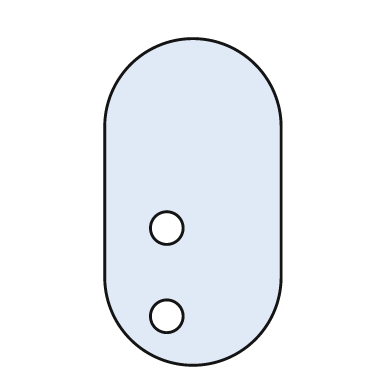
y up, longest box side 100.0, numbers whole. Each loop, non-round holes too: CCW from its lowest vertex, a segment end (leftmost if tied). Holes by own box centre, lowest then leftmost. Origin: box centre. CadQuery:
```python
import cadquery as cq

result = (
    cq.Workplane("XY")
    .moveTo(-27.0, -23.0)
    .threePointArc((0.0, -50.0), (27.0, -23.0))
    .lineTo(27.0, 23.0)
    .threePointArc((0.0, 50.0), (-27.0, 23.0))
    .close()
    .moveTo(-8.0, -35.0)
    .circle(5.0)
    .moveTo(-8.0, -8.0)
    .circle(5.0)
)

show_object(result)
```